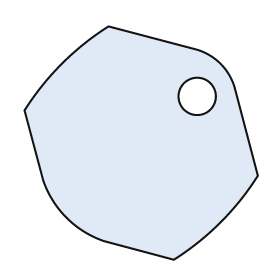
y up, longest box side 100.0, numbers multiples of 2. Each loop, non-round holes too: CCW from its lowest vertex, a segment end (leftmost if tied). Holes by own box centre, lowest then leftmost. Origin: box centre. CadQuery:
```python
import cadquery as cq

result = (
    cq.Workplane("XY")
    .moveTo(14.0, -50.0)
    .threePointArc((34.0, -34.0), (50.0, -14.0))
    .lineTo(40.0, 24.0)
    .threePointArc((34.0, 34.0), (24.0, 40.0))
    .lineTo(-14.0, 50.0)
    .threePointArc((-34.0, 34.0), (-50.0, 14.0))
    .lineTo(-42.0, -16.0)
    .threePointArc((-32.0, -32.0), (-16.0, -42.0))
    .close()
    .moveTo(24.0, 20.0)
    .circle(8.0)
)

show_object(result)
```